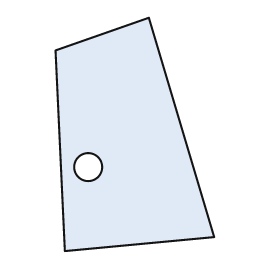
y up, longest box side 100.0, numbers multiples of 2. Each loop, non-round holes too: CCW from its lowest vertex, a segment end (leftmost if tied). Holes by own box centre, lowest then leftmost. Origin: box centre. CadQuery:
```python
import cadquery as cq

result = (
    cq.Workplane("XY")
    .moveTo(-30.0, -50.0)
    .lineTo(34.0, -44.0)
    .lineTo(6.0, 50.0)
    .lineTo(-34.0, 36.0)
    .close()
    .moveTo(-20.0, -14.0)
    .circle(6.0)
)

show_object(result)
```